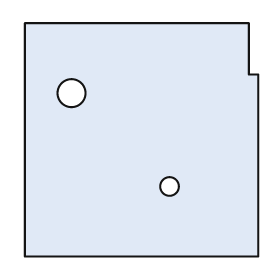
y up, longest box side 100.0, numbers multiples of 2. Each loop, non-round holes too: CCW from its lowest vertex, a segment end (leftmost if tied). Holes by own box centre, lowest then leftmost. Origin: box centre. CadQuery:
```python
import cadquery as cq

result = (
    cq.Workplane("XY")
    .moveTo(-50.0, -50.0)
    .lineTo(50.0, -50.0)
    .lineTo(50.0, 28.0)
    .lineTo(46.0, 28.0)
    .lineTo(46.0, 50.0)
    .lineTo(-50.0, 50.0)
    .close()
    .moveTo(12.0, -20.0)
    .circle(4.0)
    .moveTo(-30.0, 20.0)
    .circle(6.0)
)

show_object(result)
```